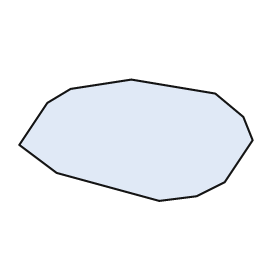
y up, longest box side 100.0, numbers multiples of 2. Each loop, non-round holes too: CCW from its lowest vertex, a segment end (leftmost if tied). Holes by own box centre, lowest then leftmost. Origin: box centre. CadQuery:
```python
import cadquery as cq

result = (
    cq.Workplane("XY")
    .moveTo(10.0, -26.0)
    .lineTo(26.0, -24.0)
    .lineTo(38.0, -18.0)
    .lineTo(50.0, 0.0)
    .lineTo(46.0, 10.0)
    .lineTo(34.0, 20.0)
    .lineTo(-2.0, 26.0)
    .lineTo(-28.0, 22.0)
    .lineTo(-38.0, 16.0)
    .lineTo(-50.0, -2.0)
    .lineTo(-34.0, -14.0)
    .close()
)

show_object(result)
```